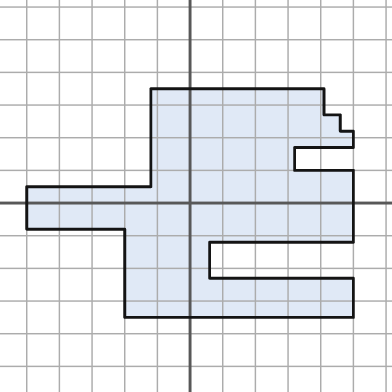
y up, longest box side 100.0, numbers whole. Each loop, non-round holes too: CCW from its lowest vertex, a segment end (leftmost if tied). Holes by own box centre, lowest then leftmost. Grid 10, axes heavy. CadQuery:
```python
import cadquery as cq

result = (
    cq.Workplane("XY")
    .moveTo(-20.0, -35.0)
    .lineTo(50.0, -35.0)
    .lineTo(50.0, -23.0)
    .lineTo(6.0, -23.0)
    .lineTo(6.0, -12.0)
    .lineTo(50.0, -12.0)
    .lineTo(50.0, 10.0)
    .lineTo(32.0, 10.0)
    .lineTo(32.0, 17.0)
    .lineTo(50.0, 17.0)
    .lineTo(50.0, 22.0)
    .lineTo(46.0, 22.0)
    .lineTo(46.0, 27.0)
    .lineTo(41.0, 27.0)
    .lineTo(41.0, 35.0)
    .lineTo(-12.0, 35.0)
    .lineTo(-12.0, 5.0)
    .lineTo(-50.0, 5.0)
    .lineTo(-50.0, -8.0)
    .lineTo(-20.0, -8.0)
    .close()
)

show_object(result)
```